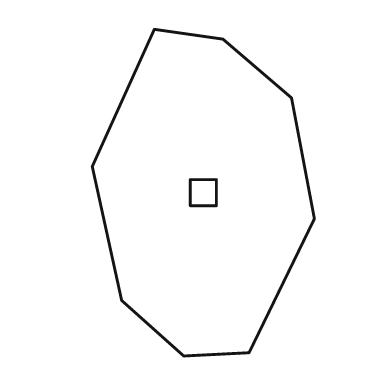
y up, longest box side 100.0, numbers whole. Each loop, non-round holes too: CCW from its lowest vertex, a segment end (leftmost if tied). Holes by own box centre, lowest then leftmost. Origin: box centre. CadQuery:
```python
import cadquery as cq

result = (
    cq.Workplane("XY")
    .moveTo(-6.0, -50.0)
    .lineTo(14.0, -49.0)
    .lineTo(34.0, -8.0)
    .lineTo(27.0, 29.0)
    .lineTo(6.0, 47.0)
    .lineTo(-15.0, 50.0)
    .lineTo(-34.0, 8.0)
    .lineTo(-25.0, -33.0)
    .close()
    .moveTo(-4.0, -4.0)
    .lineTo(4.0, -4.0)
    .lineTo(4.0, 4.0)
    .lineTo(-4.0, 4.0)
    .close()
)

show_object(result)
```